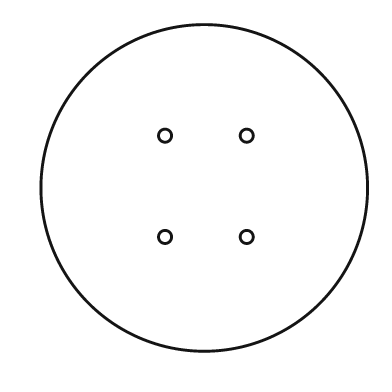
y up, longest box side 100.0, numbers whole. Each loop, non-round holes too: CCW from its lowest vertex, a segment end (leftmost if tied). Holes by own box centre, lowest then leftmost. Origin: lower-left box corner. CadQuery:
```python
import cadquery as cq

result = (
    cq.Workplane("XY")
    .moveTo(50.0, 50.0)
    .circle(50.0)
    .moveTo(38.0, 35.0)
    .circle(2.0)
    .moveTo(63.0, 35.0)
    .circle(2.0)
    .moveTo(38.0, 66.0)
    .circle(2.0)
    .moveTo(63.0, 66.0)
    .circle(2.0)
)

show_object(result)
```